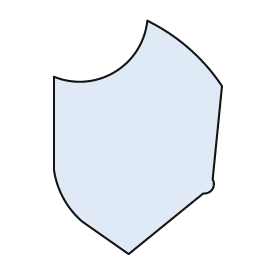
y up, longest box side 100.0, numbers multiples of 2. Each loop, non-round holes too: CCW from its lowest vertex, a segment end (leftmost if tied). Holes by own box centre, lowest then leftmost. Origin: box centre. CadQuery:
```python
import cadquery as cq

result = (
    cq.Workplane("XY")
    .moveTo(-4.0, -50.0)
    .lineTo(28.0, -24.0)
    .threePointArc((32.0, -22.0), (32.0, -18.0))
    .lineTo(36.0, 22.0)
    .threePointArc((22.0, 38.0), (4.0, 50.0))
    .threePointArc((-10.0, 28.0), (-36.0, 26.0))
    .lineTo(-36.0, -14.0)
    .threePointArc((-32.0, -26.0), (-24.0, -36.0))
    .close()
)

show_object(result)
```